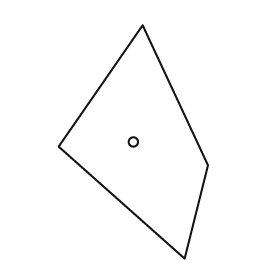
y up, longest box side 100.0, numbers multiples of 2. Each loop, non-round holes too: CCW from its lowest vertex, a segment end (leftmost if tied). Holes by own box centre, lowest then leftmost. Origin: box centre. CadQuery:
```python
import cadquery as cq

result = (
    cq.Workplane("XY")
    .moveTo(22.0, -50.0)
    .lineTo(32.0, -10.0)
    .lineTo(4.0, 50.0)
    .lineTo(-32.0, -2.0)
    .close()
    .moveTo(0.0, 0.0)
    .circle(2.0)
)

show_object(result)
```